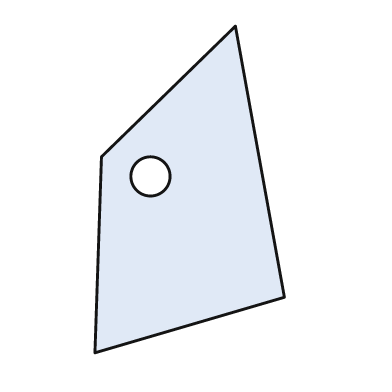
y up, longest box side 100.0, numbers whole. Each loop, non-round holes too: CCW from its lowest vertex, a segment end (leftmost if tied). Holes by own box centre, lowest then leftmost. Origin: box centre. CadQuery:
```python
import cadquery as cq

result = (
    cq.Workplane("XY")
    .moveTo(-29.0, -50.0)
    .lineTo(29.0, -33.0)
    .lineTo(14.0, 50.0)
    .lineTo(-27.0, 10.0)
    .close()
    .moveTo(-12.0, 4.0)
    .circle(6.0)
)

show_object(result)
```